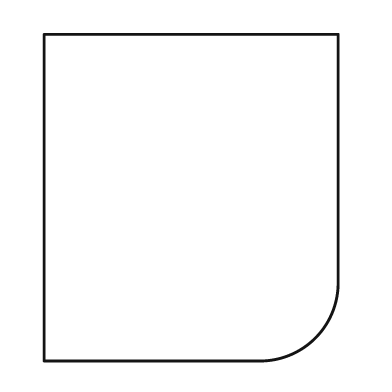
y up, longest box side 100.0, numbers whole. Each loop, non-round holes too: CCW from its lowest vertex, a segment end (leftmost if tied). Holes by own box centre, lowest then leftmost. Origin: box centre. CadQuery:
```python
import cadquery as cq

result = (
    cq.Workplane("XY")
    .moveTo(-45.0, -50.0)
    .lineTo(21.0, -50.0)
    .threePointArc((38.0, -43.0), (45.0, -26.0))
    .lineTo(45.0, 50.0)
    .lineTo(-45.0, 50.0)
    .close()
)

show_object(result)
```